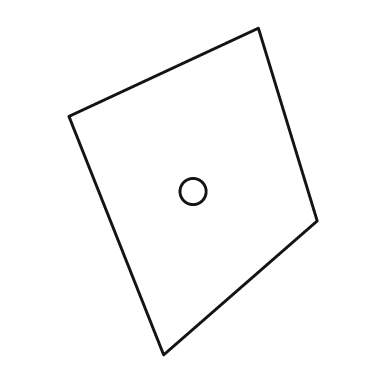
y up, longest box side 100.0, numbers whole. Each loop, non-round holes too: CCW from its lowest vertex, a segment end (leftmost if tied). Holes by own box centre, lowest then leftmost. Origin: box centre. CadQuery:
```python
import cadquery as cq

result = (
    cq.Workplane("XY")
    .moveTo(-9.0, -50.0)
    .lineTo(38.0, -9.0)
    .lineTo(20.0, 50.0)
    .lineTo(-38.0, 23.0)
    .close()
    .moveTo(0.0, 0.0)
    .circle(4.0)
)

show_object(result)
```